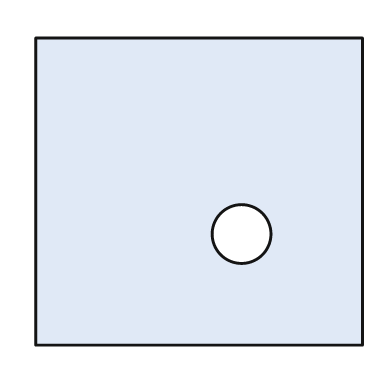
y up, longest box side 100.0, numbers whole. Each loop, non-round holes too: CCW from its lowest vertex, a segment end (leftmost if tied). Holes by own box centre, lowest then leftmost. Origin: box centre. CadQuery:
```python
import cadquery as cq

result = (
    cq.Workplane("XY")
    .moveTo(-50.0, -47.0)
    .lineTo(50.0, -47.0)
    .lineTo(50.0, 47.0)
    .lineTo(-50.0, 47.0)
    .close()
    .moveTo(13.0, -13.0)
    .circle(9.0)
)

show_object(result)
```